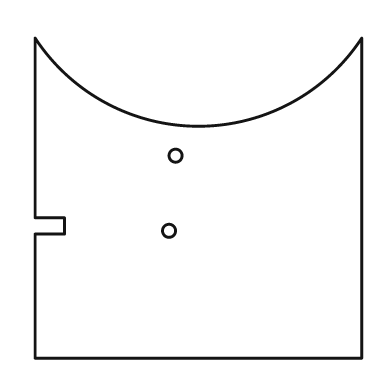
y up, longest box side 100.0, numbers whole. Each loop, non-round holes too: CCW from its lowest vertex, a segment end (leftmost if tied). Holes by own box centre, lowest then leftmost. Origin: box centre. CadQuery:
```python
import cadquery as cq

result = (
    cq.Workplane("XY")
    .moveTo(-50.0, -49.0)
    .lineTo(50.0, -49.0)
    .lineTo(50.0, 49.0)
    .threePointArc((0.0, 22.0), (-50.0, 49.0))
    .lineTo(-50.0, -6.0)
    .lineTo(-41.0, -6.0)
    .lineTo(-41.0, -11.0)
    .lineTo(-50.0, -11.0)
    .close()
    .moveTo(-9.0, -10.0)
    .circle(2.0)
    .moveTo(-7.0, 13.0)
    .circle(2.0)
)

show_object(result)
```